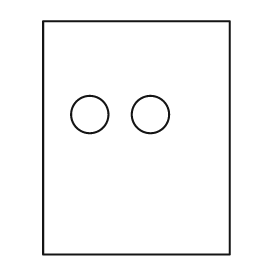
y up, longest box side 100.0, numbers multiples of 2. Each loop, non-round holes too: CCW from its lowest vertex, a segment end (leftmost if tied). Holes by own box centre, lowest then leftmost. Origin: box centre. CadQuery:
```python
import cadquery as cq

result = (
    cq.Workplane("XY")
    .moveTo(-40.0, -50.0)
    .lineTo(40.0, -50.0)
    .lineTo(40.0, 50.0)
    .lineTo(-40.0, 50.0)
    .close()
    .moveTo(-20.0, 10.0)
    .circle(8.0)
    .moveTo(6.0, 10.0)
    .circle(8.0)
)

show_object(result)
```